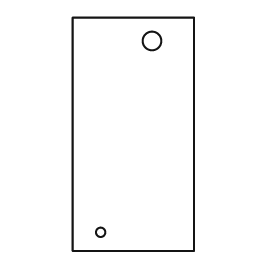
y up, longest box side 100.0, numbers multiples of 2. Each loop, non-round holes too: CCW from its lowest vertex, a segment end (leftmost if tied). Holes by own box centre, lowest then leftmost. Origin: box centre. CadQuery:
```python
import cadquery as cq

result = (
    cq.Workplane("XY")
    .moveTo(-26.0, -50.0)
    .lineTo(26.0, -50.0)
    .lineTo(26.0, 50.0)
    .lineTo(-26.0, 50.0)
    .close()
    .moveTo(-14.0, -42.0)
    .circle(2.0)
    .moveTo(8.0, 40.0)
    .circle(4.0)
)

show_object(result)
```